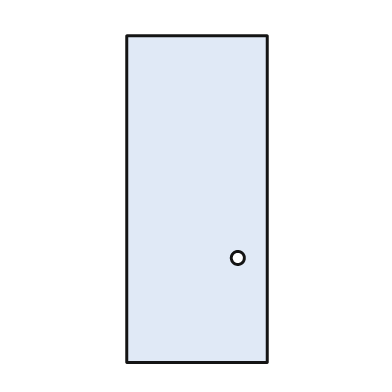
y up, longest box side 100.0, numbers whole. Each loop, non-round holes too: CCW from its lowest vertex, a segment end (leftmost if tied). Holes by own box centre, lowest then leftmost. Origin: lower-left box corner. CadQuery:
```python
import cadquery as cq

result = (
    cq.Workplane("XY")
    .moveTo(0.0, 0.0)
    .lineTo(43.0, 0.0)
    .lineTo(43.0, 100.0)
    .lineTo(0.0, 100.0)
    .close()
    .moveTo(34.0, 32.0)
    .circle(2.0)
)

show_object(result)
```